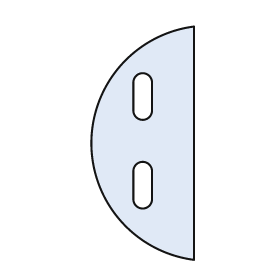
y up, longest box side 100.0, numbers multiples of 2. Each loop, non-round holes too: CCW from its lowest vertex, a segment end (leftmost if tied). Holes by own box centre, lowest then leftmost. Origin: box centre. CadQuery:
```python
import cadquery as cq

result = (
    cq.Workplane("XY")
    .moveTo(22.0, -50.0)
    .lineTo(22.0, 50.0)
    .threePointArc((-22.0, 0.0), (22.0, -50.0))
    .close()
    .moveTo(-4.0, -24.0)
    .threePointArc((0.0, -28.0), (4.0, -24.0))
    .lineTo(4.0, -12.0)
    .threePointArc((0.0, -8.0), (-4.0, -12.0))
    .close()
    .moveTo(-4.0, 14.0)
    .threePointArc((0.0, 10.0), (4.0, 14.0))
    .lineTo(4.0, 26.0)
    .threePointArc((0.0, 30.0), (-4.0, 26.0))
    .close()
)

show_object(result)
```